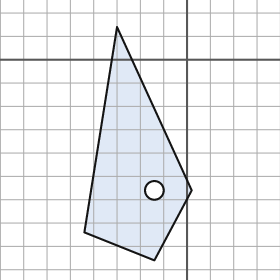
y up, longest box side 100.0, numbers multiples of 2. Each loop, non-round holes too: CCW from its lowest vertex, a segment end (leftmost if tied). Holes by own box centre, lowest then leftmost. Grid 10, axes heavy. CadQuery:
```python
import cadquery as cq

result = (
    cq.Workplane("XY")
    .moveTo(-14.0, -86.0)
    .lineTo(2.0, -56.0)
    .lineTo(-30.0, 14.0)
    .lineTo(-44.0, -74.0)
    .close()
    .moveTo(-14.0, -56.0)
    .circle(4.0)
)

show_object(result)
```